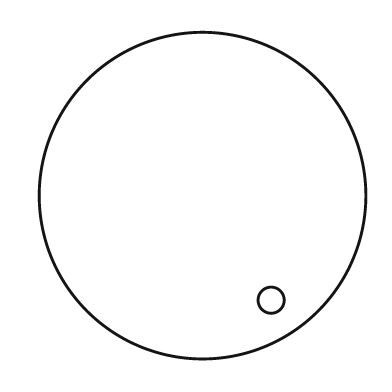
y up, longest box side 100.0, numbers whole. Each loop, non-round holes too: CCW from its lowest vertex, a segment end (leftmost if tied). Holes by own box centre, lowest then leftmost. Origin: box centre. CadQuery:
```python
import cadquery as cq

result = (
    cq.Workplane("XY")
    .moveTo(0.0, 0.0)
    .circle(50.0)
    .moveTo(21.0, -32.0)
    .circle(4.0)
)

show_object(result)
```